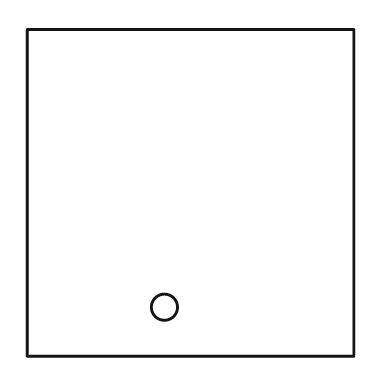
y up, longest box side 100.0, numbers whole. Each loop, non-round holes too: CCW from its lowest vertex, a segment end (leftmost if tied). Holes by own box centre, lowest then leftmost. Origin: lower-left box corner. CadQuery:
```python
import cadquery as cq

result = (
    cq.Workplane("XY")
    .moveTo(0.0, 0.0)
    .lineTo(100.0, 0.0)
    .lineTo(100.0, 100.0)
    .lineTo(0.0, 100.0)
    .close()
    .moveTo(42.0, 15.0)
    .circle(4.0)
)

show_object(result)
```